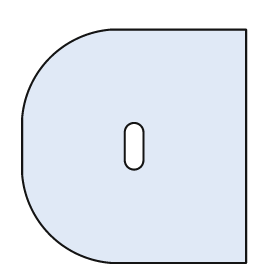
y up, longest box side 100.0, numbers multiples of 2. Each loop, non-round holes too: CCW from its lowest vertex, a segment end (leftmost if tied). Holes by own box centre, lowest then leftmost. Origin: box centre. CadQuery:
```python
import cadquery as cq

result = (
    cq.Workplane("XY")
    .moveTo(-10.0, -50.0)
    .lineTo(48.0, -50.0)
    .lineTo(48.0, 50.0)
    .lineTo(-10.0, 50.0)
    .threePointArc((-36.0, 38.0), (-48.0, 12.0))
    .lineTo(-48.0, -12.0)
    .threePointArc((-36.0, -38.0), (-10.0, -50.0))
    .close()
    .moveTo(-4.0, -6.0)
    .threePointArc((0.0, -10.0), (4.0, -6.0))
    .lineTo(4.0, 6.0)
    .threePointArc((0.0, 10.0), (-4.0, 6.0))
    .close()
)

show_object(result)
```